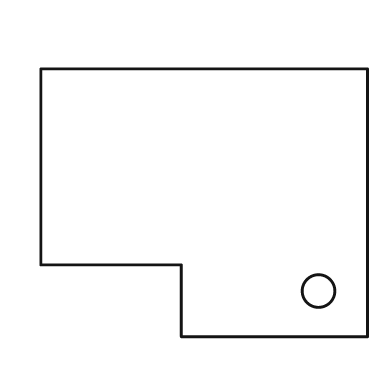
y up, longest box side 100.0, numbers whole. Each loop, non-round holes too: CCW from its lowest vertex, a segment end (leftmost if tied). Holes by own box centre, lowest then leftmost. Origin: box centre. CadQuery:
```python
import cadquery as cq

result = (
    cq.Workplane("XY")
    .moveTo(-7.0, -41.0)
    .lineTo(50.0, -41.0)
    .lineTo(50.0, 41.0)
    .lineTo(-50.0, 41.0)
    .lineTo(-50.0, -19.0)
    .lineTo(-7.0, -19.0)
    .close()
    .moveTo(35.0, -27.0)
    .circle(5.0)
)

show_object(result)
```